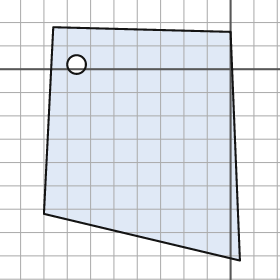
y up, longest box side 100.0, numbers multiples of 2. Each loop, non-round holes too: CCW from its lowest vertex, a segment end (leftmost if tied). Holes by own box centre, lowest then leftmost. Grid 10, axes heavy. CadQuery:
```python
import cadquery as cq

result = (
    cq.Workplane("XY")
    .moveTo(4.0, -82.0)
    .lineTo(0.0, 16.0)
    .lineTo(-76.0, 18.0)
    .lineTo(-80.0, -62.0)
    .close()
    .moveTo(-66.0, 2.0)
    .circle(4.0)
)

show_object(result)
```